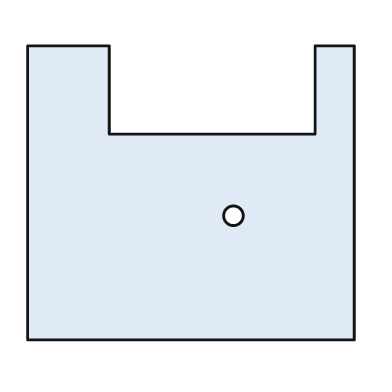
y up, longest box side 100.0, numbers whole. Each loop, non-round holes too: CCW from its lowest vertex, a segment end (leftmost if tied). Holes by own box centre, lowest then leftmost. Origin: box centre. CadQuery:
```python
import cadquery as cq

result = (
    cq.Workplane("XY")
    .moveTo(-50.0, -45.0)
    .lineTo(50.0, -45.0)
    .lineTo(50.0, 45.0)
    .lineTo(38.0, 45.0)
    .lineTo(38.0, 18.0)
    .lineTo(-25.0, 18.0)
    .lineTo(-25.0, 45.0)
    .lineTo(-50.0, 45.0)
    .close()
    .moveTo(13.0, -7.0)
    .circle(3.0)
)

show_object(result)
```